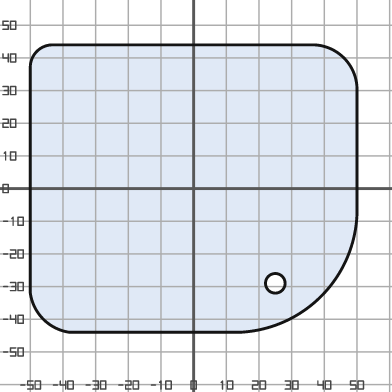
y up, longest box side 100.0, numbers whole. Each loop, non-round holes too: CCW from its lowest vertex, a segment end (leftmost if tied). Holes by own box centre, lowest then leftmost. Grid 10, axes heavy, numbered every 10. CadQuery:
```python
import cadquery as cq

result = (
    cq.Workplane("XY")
    .moveTo(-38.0, -44.0)
    .lineTo(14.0, -44.0)
    .threePointArc((39.0, -33.0), (50.0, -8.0))
    .lineTo(50.0, 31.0)
    .threePointArc((46.0, 40.0), (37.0, 44.0))
    .lineTo(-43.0, 44.0)
    .threePointArc((-48.0, 42.0), (-50.0, 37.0))
    .lineTo(-50.0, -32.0)
    .threePointArc((-46.0, -40.0), (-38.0, -44.0))
    .close()
    .moveTo(25.0, -29.0)
    .circle(3.0)
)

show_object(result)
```